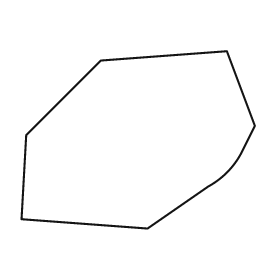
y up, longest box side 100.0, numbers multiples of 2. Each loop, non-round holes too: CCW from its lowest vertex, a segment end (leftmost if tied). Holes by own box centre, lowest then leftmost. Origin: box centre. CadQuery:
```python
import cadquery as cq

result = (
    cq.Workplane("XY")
    .moveTo(4.0, -38.0)
    .lineTo(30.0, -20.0)
    .threePointArc((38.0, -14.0), (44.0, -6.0))
    .lineTo(50.0, 6.0)
    .lineTo(38.0, 38.0)
    .lineTo(-16.0, 34.0)
    .lineTo(-48.0, 2.0)
    .lineTo(-50.0, -34.0)
    .close()
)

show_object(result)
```